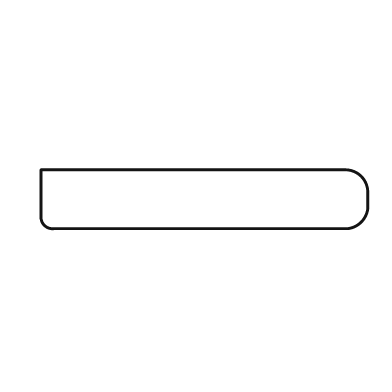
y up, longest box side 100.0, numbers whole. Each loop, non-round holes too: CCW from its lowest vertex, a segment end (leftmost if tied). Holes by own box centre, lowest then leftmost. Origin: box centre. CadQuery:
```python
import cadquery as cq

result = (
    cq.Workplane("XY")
    .moveTo(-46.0, -9.0)
    .lineTo(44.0, -9.0)
    .threePointArc((48.0, -7.0), (50.0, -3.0))
    .lineTo(50.0, 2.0)
    .threePointArc((48.0, 7.0), (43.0, 9.0))
    .lineTo(-50.0, 9.0)
    .lineTo(-50.0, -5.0)
    .threePointArc((-49.0, -8.0), (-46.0, -9.0))
    .close()
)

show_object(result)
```